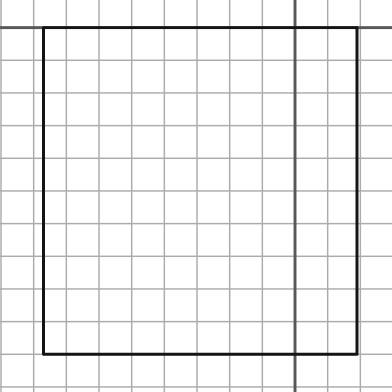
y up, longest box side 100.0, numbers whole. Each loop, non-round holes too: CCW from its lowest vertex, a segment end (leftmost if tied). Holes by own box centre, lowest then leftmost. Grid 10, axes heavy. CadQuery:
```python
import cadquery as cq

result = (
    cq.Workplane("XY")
    .moveTo(-77.0, -100.0)
    .lineTo(19.0, -100.0)
    .lineTo(19.0, 0.0)
    .lineTo(-77.0, 0.0)
    .close()
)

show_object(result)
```